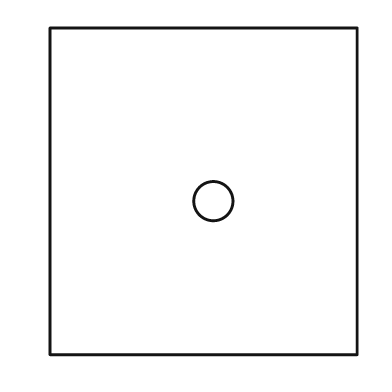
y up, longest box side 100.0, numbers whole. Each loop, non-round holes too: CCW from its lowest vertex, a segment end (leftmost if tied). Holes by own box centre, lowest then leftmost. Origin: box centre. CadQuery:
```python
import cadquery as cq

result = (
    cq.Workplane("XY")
    .moveTo(-47.0, -50.0)
    .lineTo(47.0, -50.0)
    .lineTo(47.0, 50.0)
    .lineTo(-47.0, 50.0)
    .close()
    .moveTo(3.0, -3.0)
    .circle(6.0)
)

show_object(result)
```